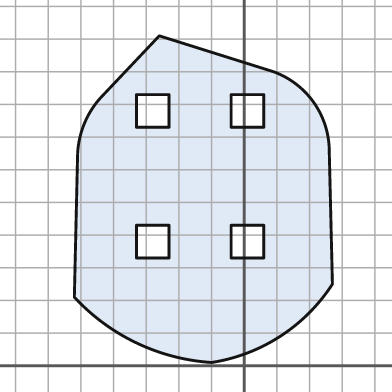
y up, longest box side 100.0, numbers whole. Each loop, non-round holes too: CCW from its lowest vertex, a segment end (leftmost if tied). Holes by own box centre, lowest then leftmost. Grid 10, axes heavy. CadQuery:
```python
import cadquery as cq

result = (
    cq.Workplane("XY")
    .moveTo(-10.0, 1.0)
    .threePointArc((11.0, 9.0), (27.0, 25.0))
    .lineTo(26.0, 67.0)
    .threePointArc((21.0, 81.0), (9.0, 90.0))
    .lineTo(-26.0, 101.0)
    .lineTo(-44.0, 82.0)
    .threePointArc((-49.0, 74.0), (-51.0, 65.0))
    .lineTo(-52.0, 21.0)
    .threePointArc((-33.0, 7.0), (-10.0, 1.0))
    .close()
    .moveTo(-33.0, 33.0)
    .lineTo(-23.0, 33.0)
    .lineTo(-23.0, 43.0)
    .lineTo(-33.0, 43.0)
    .close()
    .moveTo(-4.0, 33.0)
    .lineTo(6.0, 33.0)
    .lineTo(6.0, 43.0)
    .lineTo(-4.0, 43.0)
    .close()
    .moveTo(-33.0, 73.0)
    .lineTo(-23.0, 73.0)
    .lineTo(-23.0, 83.0)
    .lineTo(-33.0, 83.0)
    .close()
    .moveTo(-4.0, 73.0)
    .lineTo(6.0, 73.0)
    .lineTo(6.0, 83.0)
    .lineTo(-4.0, 83.0)
    .close()
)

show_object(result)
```